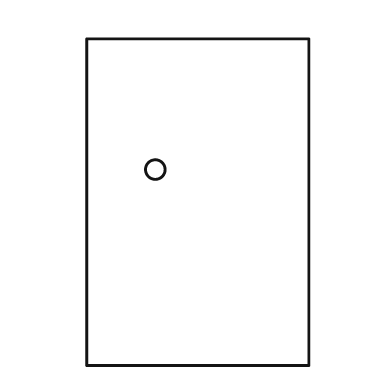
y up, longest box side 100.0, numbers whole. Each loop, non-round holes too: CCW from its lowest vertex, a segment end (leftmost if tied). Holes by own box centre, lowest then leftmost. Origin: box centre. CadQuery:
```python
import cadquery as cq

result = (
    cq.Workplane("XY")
    .moveTo(-34.0, -50.0)
    .lineTo(34.0, -50.0)
    .lineTo(34.0, 50.0)
    .lineTo(-34.0, 50.0)
    .close()
    .moveTo(-13.0, 10.0)
    .circle(3.0)
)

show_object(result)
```